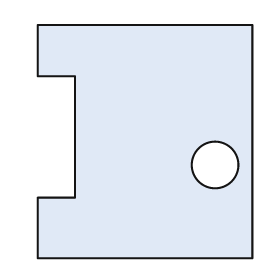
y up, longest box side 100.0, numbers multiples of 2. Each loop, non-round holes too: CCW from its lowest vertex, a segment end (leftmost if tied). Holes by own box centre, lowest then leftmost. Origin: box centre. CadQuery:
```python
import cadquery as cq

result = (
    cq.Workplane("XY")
    .moveTo(-46.0, -50.0)
    .lineTo(46.0, -50.0)
    .lineTo(46.0, 50.0)
    .lineTo(-46.0, 50.0)
    .lineTo(-46.0, 28.0)
    .lineTo(-30.0, 28.0)
    .lineTo(-30.0, -24.0)
    .lineTo(-46.0, -24.0)
    .close()
    .moveTo(30.0, -10.0)
    .circle(10.0)
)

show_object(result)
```